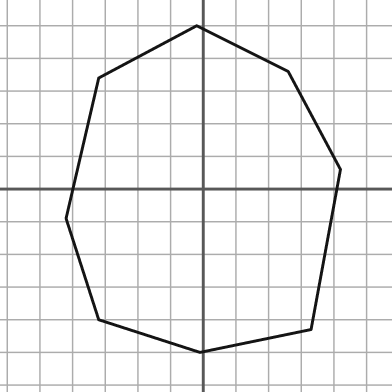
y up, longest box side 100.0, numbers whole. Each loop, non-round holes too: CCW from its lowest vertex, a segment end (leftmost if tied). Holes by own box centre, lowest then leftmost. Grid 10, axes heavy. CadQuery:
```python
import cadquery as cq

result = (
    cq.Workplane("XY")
    .moveTo(-1.0, -50.0)
    .lineTo(33.0, -43.0)
    .lineTo(42.0, 6.0)
    .lineTo(26.0, 36.0)
    .lineTo(-2.0, 50.0)
    .lineTo(-32.0, 34.0)
    .lineTo(-42.0, -9.0)
    .lineTo(-32.0, -40.0)
    .close()
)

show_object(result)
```